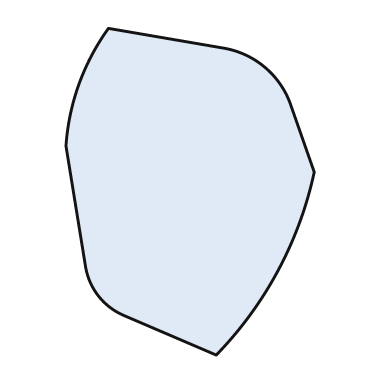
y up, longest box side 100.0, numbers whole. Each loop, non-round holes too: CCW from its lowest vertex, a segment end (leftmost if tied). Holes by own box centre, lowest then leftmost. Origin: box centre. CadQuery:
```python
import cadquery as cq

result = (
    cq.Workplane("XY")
    .moveTo(8.0, -50.0)
    .threePointArc((27.0, -24.0), (38.0, 6.0))
    .lineTo(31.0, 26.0)
    .threePointArc((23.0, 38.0), (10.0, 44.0))
    .lineTo(-25.0, 50.0)
    .threePointArc((-34.0, 33.0), (-38.0, 14.0))
    .lineTo(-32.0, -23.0)
    .threePointArc((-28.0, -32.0), (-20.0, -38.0))
    .close()
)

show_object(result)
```